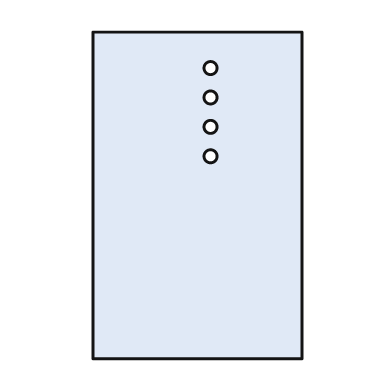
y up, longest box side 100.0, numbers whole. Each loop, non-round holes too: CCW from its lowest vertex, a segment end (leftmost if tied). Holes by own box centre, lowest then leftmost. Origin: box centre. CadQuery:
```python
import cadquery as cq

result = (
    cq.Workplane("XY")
    .moveTo(-32.0, -50.0)
    .lineTo(32.0, -50.0)
    .lineTo(32.0, 50.0)
    .lineTo(-32.0, 50.0)
    .close()
    .moveTo(4.0, 12.0)
    .circle(2.0)
    .moveTo(4.0, 21.0)
    .circle(2.0)
    .moveTo(4.0, 30.0)
    .circle(2.0)
    .moveTo(4.0, 39.0)
    .circle(2.0)
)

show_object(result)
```